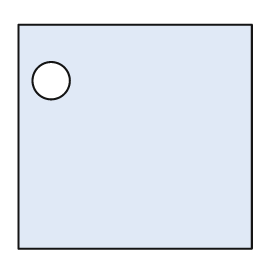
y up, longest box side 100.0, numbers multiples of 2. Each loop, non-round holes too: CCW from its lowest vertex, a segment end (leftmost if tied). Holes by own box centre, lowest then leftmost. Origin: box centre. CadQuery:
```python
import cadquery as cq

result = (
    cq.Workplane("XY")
    .moveTo(-50.0, -48.0)
    .lineTo(50.0, -48.0)
    .lineTo(50.0, 48.0)
    .lineTo(-50.0, 48.0)
    .close()
    .moveTo(-36.0, 24.0)
    .circle(8.0)
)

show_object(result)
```